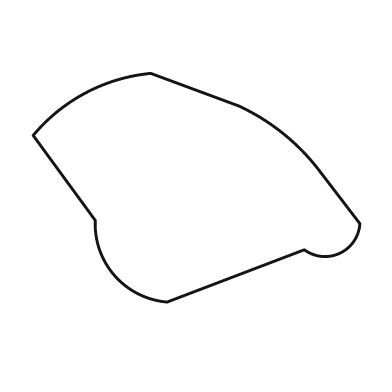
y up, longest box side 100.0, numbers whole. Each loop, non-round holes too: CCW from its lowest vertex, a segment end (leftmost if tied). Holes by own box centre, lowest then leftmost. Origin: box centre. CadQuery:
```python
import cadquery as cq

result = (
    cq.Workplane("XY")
    .moveTo(-9.0, -35.0)
    .lineTo(33.0, -19.0)
    .threePointArc((44.0, -20.0), (50.0, -11.0))
    .lineTo(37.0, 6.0)
    .threePointArc((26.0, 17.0), (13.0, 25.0))
    .lineTo(-14.0, 35.0)
    .threePointArc((-34.0, 29.0), (-50.0, 16.0))
    .lineTo(-31.0, -10.0)
    .threePointArc((-25.0, -27.0), (-9.0, -35.0))
    .close()
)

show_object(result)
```